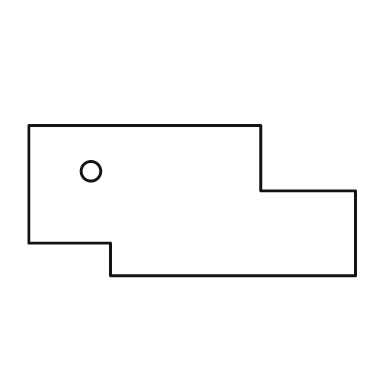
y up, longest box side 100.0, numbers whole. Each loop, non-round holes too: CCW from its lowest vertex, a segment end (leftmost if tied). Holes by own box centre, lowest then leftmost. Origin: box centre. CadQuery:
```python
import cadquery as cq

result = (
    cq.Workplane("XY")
    .moveTo(-25.0, -23.0)
    .lineTo(50.0, -23.0)
    .lineTo(50.0, 3.0)
    .lineTo(21.0, 3.0)
    .lineTo(21.0, 23.0)
    .lineTo(-50.0, 23.0)
    .lineTo(-50.0, -13.0)
    .lineTo(-25.0, -13.0)
    .close()
    .moveTo(-31.0, 9.0)
    .circle(3.0)
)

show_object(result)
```